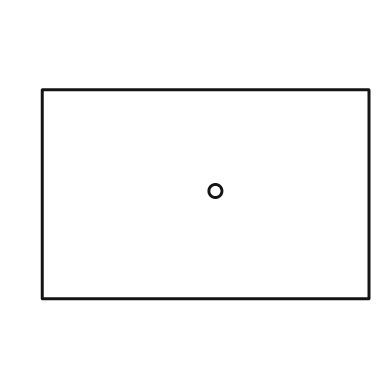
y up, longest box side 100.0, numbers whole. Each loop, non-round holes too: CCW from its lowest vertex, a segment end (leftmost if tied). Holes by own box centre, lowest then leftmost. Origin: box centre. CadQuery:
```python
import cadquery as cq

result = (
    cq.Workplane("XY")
    .moveTo(-50.0, -32.0)
    .lineTo(50.0, -32.0)
    .lineTo(50.0, 32.0)
    .lineTo(-50.0, 32.0)
    .close()
    .moveTo(3.0, 1.0)
    .circle(2.0)
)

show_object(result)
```